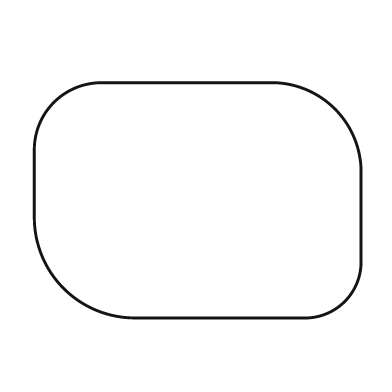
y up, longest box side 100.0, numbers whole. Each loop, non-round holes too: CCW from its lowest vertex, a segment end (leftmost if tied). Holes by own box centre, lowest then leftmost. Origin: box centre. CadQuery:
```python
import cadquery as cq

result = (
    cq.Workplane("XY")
    .moveTo(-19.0, -36.0)
    .lineTo(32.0, -36.0)
    .threePointArc((45.0, -31.0), (50.0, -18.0))
    .lineTo(50.0, 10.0)
    .threePointArc((42.0, 28.0), (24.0, 36.0))
    .lineTo(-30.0, 36.0)
    .threePointArc((-44.0, 30.0), (-50.0, 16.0))
    .lineTo(-50.0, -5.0)
    .threePointArc((-41.0, -27.0), (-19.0, -36.0))
    .close()
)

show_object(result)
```